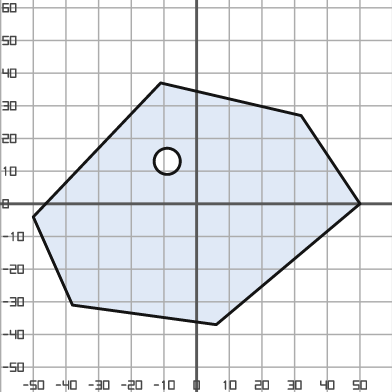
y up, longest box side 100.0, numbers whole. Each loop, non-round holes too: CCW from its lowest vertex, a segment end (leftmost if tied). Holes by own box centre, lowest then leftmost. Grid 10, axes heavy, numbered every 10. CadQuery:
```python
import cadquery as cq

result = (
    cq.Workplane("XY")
    .moveTo(6.0, -37.0)
    .lineTo(50.0, 0.0)
    .lineTo(32.0, 27.0)
    .lineTo(-11.0, 37.0)
    .lineTo(-50.0, -4.0)
    .lineTo(-38.0, -31.0)
    .close()
    .moveTo(-9.0, 13.0)
    .circle(4.0)
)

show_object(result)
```